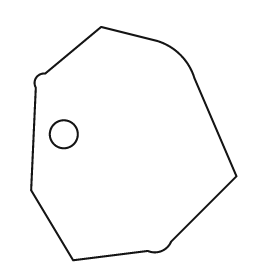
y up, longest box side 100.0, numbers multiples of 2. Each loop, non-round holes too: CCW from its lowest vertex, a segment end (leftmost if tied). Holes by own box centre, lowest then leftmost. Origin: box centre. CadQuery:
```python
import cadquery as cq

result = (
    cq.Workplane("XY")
    .moveTo(-26.0, -50.0)
    .lineTo(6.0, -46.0)
    .threePointArc((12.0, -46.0), (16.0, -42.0))
    .lineTo(44.0, -14.0)
    .lineTo(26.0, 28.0)
    .threePointArc((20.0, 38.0), (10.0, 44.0))
    .lineTo(-14.0, 50.0)
    .lineTo(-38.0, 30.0)
    .threePointArc((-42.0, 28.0), (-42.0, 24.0))
    .lineTo(-44.0, -20.0)
    .close()
    .moveTo(-30.0, 4.0)
    .circle(6.0)
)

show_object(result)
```